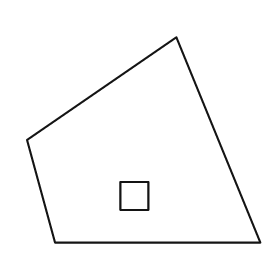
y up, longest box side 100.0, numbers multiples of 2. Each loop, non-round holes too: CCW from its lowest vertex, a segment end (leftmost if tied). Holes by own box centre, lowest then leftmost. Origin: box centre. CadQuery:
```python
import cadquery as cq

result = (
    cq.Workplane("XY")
    .moveTo(-38.0, -44.0)
    .lineTo(50.0, -44.0)
    .lineTo(14.0, 44.0)
    .lineTo(-50.0, 0.0)
    .close()
    .moveTo(-10.0, -30.0)
    .lineTo(2.0, -30.0)
    .lineTo(2.0, -18.0)
    .lineTo(-10.0, -18.0)
    .close()
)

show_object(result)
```